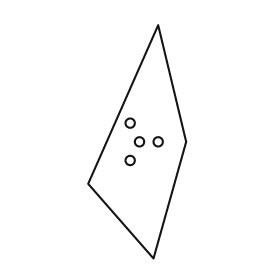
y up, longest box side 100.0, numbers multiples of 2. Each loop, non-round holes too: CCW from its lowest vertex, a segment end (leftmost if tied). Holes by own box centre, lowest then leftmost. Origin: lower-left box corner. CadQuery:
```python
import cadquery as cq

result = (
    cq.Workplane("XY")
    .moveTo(28.0, 0.0)
    .lineTo(42.0, 50.0)
    .lineTo(30.0, 100.0)
    .lineTo(0.0, 32.0)
    .close()
    .moveTo(18.0, 42.0)
    .circle(2.0)
    .moveTo(22.0, 50.0)
    .circle(2.0)
    .moveTo(30.0, 50.0)
    .circle(2.0)
    .moveTo(18.0, 58.0)
    .circle(2.0)
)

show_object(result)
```